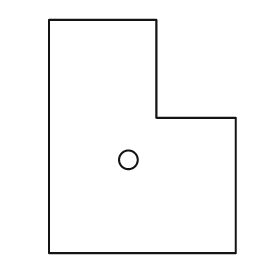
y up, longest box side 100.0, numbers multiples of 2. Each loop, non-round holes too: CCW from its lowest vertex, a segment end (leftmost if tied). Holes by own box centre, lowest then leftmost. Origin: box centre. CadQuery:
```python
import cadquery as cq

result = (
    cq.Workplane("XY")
    .moveTo(-40.0, -50.0)
    .lineTo(40.0, -50.0)
    .lineTo(40.0, 8.0)
    .lineTo(6.0, 8.0)
    .lineTo(6.0, 50.0)
    .lineTo(-40.0, 50.0)
    .close()
    .moveTo(-6.0, -10.0)
    .circle(4.0)
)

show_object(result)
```